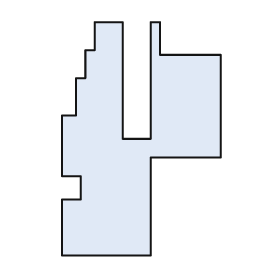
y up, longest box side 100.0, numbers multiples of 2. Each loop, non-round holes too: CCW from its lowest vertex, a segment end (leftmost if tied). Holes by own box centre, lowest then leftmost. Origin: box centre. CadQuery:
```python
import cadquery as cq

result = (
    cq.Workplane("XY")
    .moveTo(-34.0, -50.0)
    .lineTo(4.0, -50.0)
    .lineTo(4.0, -8.0)
    .lineTo(34.0, -8.0)
    .lineTo(34.0, 36.0)
    .lineTo(8.0, 36.0)
    .lineTo(8.0, 50.0)
    .lineTo(4.0, 50.0)
    .lineTo(4.0, 0.0)
    .lineTo(-8.0, 0.0)
    .lineTo(-8.0, 50.0)
    .lineTo(-20.0, 50.0)
    .lineTo(-20.0, 38.0)
    .lineTo(-24.0, 38.0)
    .lineTo(-24.0, 26.0)
    .lineTo(-28.0, 26.0)
    .lineTo(-28.0, 10.0)
    .lineTo(-34.0, 10.0)
    .lineTo(-34.0, -16.0)
    .lineTo(-26.0, -16.0)
    .lineTo(-26.0, -26.0)
    .lineTo(-34.0, -26.0)
    .close()
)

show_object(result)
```